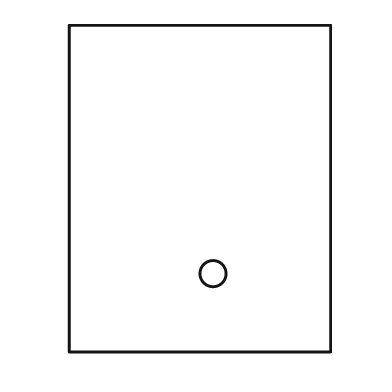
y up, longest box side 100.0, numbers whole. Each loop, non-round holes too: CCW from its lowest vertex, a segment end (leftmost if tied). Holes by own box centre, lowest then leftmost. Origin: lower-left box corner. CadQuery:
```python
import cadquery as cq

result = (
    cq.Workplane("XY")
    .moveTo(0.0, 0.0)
    .lineTo(80.0, 0.0)
    .lineTo(80.0, 100.0)
    .lineTo(0.0, 100.0)
    .close()
    .moveTo(44.0, 24.0)
    .circle(4.0)
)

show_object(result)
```